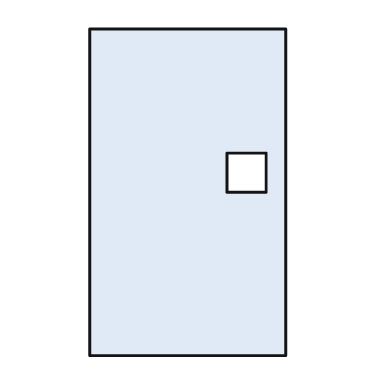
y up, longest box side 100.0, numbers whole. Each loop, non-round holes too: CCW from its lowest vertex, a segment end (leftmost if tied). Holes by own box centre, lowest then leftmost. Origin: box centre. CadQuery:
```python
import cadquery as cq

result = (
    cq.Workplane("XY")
    .moveTo(-30.0, -50.0)
    .lineTo(30.0, -50.0)
    .lineTo(30.0, 50.0)
    .lineTo(-30.0, 50.0)
    .close()
    .moveTo(12.0, 0.0)
    .lineTo(24.0, 0.0)
    .lineTo(24.0, 12.0)
    .lineTo(12.0, 12.0)
    .close()
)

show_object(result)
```